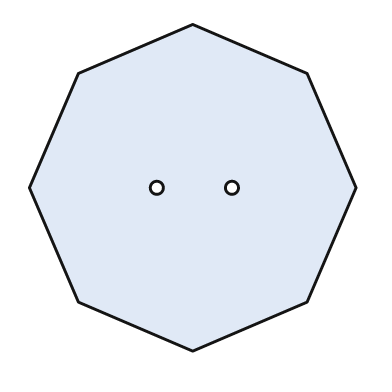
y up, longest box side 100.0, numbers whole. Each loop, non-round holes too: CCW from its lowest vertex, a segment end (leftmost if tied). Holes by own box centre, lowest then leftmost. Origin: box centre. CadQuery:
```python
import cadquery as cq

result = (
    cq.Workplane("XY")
    .moveTo(0.0, -50.0)
    .lineTo(35.0, -35.0)
    .lineTo(50.0, 0.0)
    .lineTo(35.0, 35.0)
    .lineTo(0.0, 50.0)
    .lineTo(-35.0, 35.0)
    .lineTo(-50.0, 0.0)
    .lineTo(-35.0, -35.0)
    .close()
    .moveTo(-11.0, 0.0)
    .circle(2.0)
    .moveTo(12.0, 0.0)
    .circle(2.0)
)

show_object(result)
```